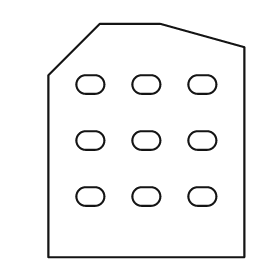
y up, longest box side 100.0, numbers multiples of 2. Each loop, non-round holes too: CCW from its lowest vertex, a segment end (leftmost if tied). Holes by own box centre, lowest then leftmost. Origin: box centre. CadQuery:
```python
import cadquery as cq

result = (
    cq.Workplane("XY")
    .moveTo(-42.0, -50.0)
    .lineTo(42.0, -50.0)
    .lineTo(42.0, 40.0)
    .lineTo(6.0, 50.0)
    .lineTo(-20.0, 50.0)
    .lineTo(-42.0, 28.0)
    .close()
    .moveTo(-26.0, -28.0)
    .lineTo(-22.0, -28.0)
    .threePointArc((-18.0, -24.0), (-22.0, -20.0))
    .lineTo(-26.0, -20.0)
    .threePointArc((-30.0, -24.0), (-26.0, -28.0))
    .close()
    .moveTo(-2.0, -28.0)
    .lineTo(2.0, -28.0)
    .threePointArc((6.0, -24.0), (2.0, -20.0))
    .lineTo(-2.0, -20.0)
    .threePointArc((-6.0, -24.0), (-2.0, -28.0))
    .close()
    .moveTo(22.0, -28.0)
    .lineTo(26.0, -28.0)
    .threePointArc((30.0, -24.0), (26.0, -20.0))
    .lineTo(22.0, -20.0)
    .threePointArc((18.0, -24.0), (22.0, -28.0))
    .close()
    .moveTo(-26.0, -4.0)
    .lineTo(-22.0, -4.0)
    .threePointArc((-18.0, 0.0), (-22.0, 4.0))
    .lineTo(-26.0, 4.0)
    .threePointArc((-30.0, 0.0), (-26.0, -4.0))
    .close()
    .moveTo(-2.0, -4.0)
    .lineTo(2.0, -4.0)
    .threePointArc((6.0, 0.0), (2.0, 4.0))
    .lineTo(-2.0, 4.0)
    .threePointArc((-6.0, 0.0), (-2.0, -4.0))
    .close()
    .moveTo(22.0, -4.0)
    .lineTo(26.0, -4.0)
    .threePointArc((30.0, 0.0), (26.0, 4.0))
    .lineTo(22.0, 4.0)
    .threePointArc((18.0, 0.0), (22.0, -4.0))
    .close()
    .moveTo(-26.0, 20.0)
    .lineTo(-22.0, 20.0)
    .threePointArc((-18.0, 24.0), (-22.0, 28.0))
    .lineTo(-26.0, 28.0)
    .threePointArc((-30.0, 24.0), (-26.0, 20.0))
    .close()
    .moveTo(-2.0, 20.0)
    .lineTo(2.0, 20.0)
    .threePointArc((6.0, 24.0), (2.0, 28.0))
    .lineTo(-2.0, 28.0)
    .threePointArc((-6.0, 24.0), (-2.0, 20.0))
    .close()
    .moveTo(22.0, 20.0)
    .lineTo(26.0, 20.0)
    .threePointArc((30.0, 24.0), (26.0, 28.0))
    .lineTo(22.0, 28.0)
    .threePointArc((18.0, 24.0), (22.0, 20.0))
    .close()
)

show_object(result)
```